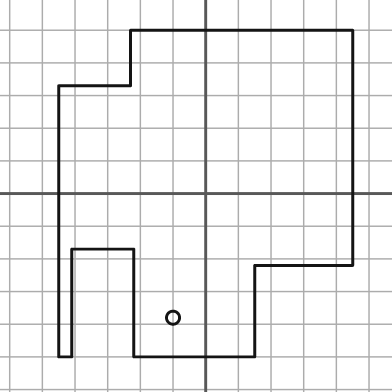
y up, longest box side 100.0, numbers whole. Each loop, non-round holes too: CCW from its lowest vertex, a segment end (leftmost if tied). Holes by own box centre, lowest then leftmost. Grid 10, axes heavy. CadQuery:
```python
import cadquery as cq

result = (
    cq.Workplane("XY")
    .moveTo(-45.0, -50.0)
    .lineTo(-41.0, -50.0)
    .lineTo(-41.0, -17.0)
    .lineTo(-22.0, -17.0)
    .lineTo(-22.0, -50.0)
    .lineTo(15.0, -50.0)
    .lineTo(15.0, -22.0)
    .lineTo(45.0, -22.0)
    .lineTo(45.0, 50.0)
    .lineTo(-23.0, 50.0)
    .lineTo(-23.0, 33.0)
    .lineTo(-45.0, 33.0)
    .close()
    .moveTo(-10.0, -38.0)
    .circle(2.0)
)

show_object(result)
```